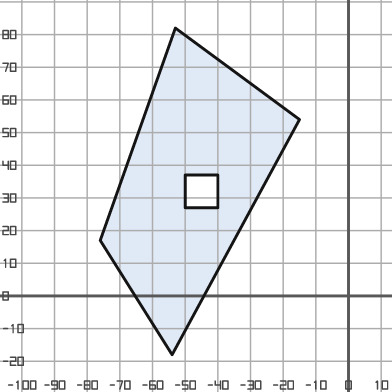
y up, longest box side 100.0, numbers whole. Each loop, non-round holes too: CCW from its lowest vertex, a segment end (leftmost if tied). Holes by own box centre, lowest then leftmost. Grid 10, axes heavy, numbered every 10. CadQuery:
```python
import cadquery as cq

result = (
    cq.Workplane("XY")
    .moveTo(-54.0, -18.0)
    .lineTo(-15.0, 54.0)
    .lineTo(-53.0, 82.0)
    .lineTo(-76.0, 17.0)
    .close()
    .moveTo(-50.0, 27.0)
    .lineTo(-40.0, 27.0)
    .lineTo(-40.0, 37.0)
    .lineTo(-50.0, 37.0)
    .close()
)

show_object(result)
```